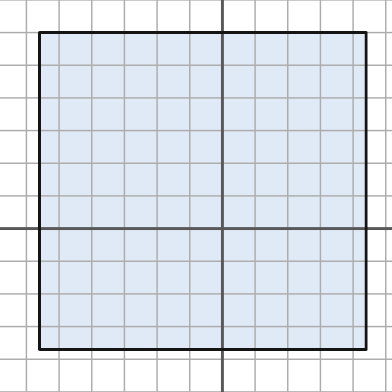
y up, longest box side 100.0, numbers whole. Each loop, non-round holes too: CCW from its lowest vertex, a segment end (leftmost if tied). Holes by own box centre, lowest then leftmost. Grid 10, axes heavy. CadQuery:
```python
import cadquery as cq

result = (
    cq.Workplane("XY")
    .moveTo(-56.0, -37.0)
    .lineTo(44.0, -37.0)
    .lineTo(44.0, 60.0)
    .lineTo(-56.0, 60.0)
    .close()
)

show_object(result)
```